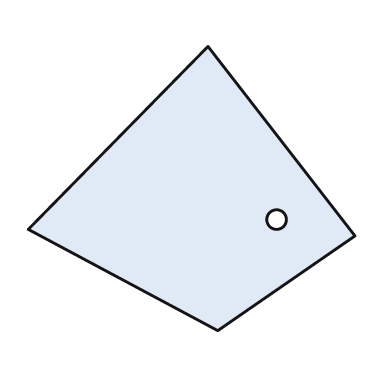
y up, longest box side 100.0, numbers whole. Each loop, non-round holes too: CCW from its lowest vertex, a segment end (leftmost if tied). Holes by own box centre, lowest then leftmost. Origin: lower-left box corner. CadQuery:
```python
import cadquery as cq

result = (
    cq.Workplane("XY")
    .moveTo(58.0, 0.0)
    .lineTo(100.0, 29.0)
    .lineTo(55.0, 87.0)
    .lineTo(0.0, 31.0)
    .close()
    .moveTo(76.0, 34.0)
    .circle(3.0)
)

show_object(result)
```